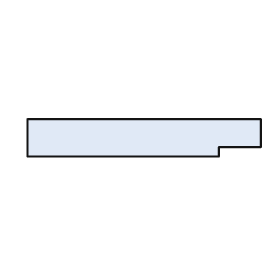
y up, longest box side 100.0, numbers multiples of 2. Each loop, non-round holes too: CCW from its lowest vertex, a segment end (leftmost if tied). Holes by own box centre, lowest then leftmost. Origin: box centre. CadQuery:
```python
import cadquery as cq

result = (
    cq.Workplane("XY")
    .moveTo(-50.0, -8.0)
    .lineTo(32.0, -8.0)
    .lineTo(32.0, -4.0)
    .lineTo(50.0, -4.0)
    .lineTo(50.0, 8.0)
    .lineTo(-50.0, 8.0)
    .close()
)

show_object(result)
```